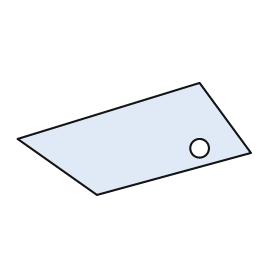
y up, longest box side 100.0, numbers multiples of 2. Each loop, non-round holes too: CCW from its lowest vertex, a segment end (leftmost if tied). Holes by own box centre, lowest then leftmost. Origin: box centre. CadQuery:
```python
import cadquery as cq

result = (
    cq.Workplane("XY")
    .moveTo(-16.0, -24.0)
    .lineTo(50.0, -6.0)
    .lineTo(28.0, 24.0)
    .lineTo(-50.0, 0.0)
    .close()
    .moveTo(28.0, -4.0)
    .circle(4.0)
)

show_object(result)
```